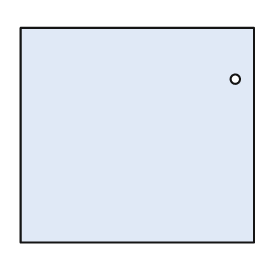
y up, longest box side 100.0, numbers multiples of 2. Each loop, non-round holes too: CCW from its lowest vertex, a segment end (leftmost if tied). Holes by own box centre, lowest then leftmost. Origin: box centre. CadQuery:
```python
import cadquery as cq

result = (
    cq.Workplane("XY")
    .moveTo(-50.0, -46.0)
    .lineTo(50.0, -46.0)
    .lineTo(50.0, 46.0)
    .lineTo(-50.0, 46.0)
    .close()
    .moveTo(42.0, 24.0)
    .circle(2.0)
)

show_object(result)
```